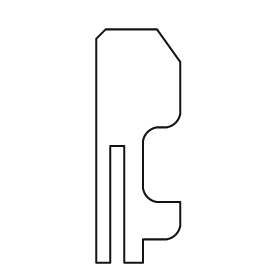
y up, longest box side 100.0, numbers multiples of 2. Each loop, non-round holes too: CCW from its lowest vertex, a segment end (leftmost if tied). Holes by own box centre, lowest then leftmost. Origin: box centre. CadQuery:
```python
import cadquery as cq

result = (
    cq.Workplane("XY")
    .moveTo(-18.0, -50.0)
    .lineTo(-12.0, -50.0)
    .lineTo(-12.0, 0.0)
    .lineTo(-6.0, 0.0)
    .lineTo(-6.0, -50.0)
    .lineTo(2.0, -50.0)
    .lineTo(2.0, -40.0)
    .lineTo(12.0, -40.0)
    .threePointArc((16.0, -38.0), (18.0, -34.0))
    .lineTo(18.0, -24.0)
    .lineTo(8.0, -24.0)
    .threePointArc((4.0, -22.0), (2.0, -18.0))
    .lineTo(2.0, 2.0)
    .threePointArc((4.0, 6.0), (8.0, 8.0))
    .lineTo(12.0, 8.0)
    .threePointArc((16.0, 10.0), (18.0, 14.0))
    .lineTo(18.0, 36.0)
    .lineTo(8.0, 50.0)
    .lineTo(-14.0, 50.0)
    .lineTo(-18.0, 46.0)
    .close()
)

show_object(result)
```